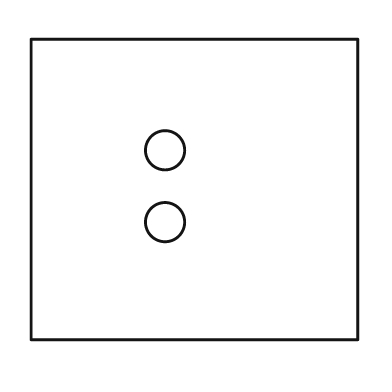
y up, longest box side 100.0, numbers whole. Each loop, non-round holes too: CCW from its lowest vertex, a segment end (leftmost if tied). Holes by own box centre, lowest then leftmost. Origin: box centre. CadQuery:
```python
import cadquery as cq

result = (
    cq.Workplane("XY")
    .moveTo(-50.0, -46.0)
    .lineTo(50.0, -46.0)
    .lineTo(50.0, 46.0)
    .lineTo(-50.0, 46.0)
    .close()
    .moveTo(-9.0, -10.0)
    .circle(6.0)
    .moveTo(-9.0, 12.0)
    .circle(6.0)
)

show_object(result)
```